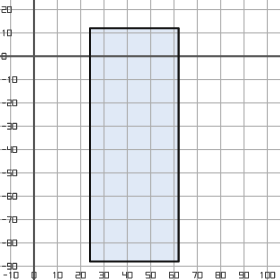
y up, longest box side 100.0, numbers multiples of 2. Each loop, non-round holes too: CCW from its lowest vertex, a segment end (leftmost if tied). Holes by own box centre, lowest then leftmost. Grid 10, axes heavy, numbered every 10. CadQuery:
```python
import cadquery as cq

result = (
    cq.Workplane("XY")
    .moveTo(24.0, -88.0)
    .lineTo(62.0, -88.0)
    .lineTo(62.0, 12.0)
    .lineTo(24.0, 12.0)
    .close()
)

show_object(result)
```